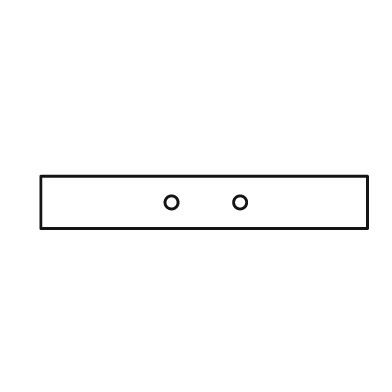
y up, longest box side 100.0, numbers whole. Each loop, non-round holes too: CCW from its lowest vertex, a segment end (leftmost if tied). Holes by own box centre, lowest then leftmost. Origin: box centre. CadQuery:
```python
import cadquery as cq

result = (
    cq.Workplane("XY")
    .moveTo(-50.0, -8.0)
    .lineTo(50.0, -8.0)
    .lineTo(50.0, 8.0)
    .lineTo(-50.0, 8.0)
    .close()
    .moveTo(-10.0, 0.0)
    .circle(2.0)
    .moveTo(11.0, 0.0)
    .circle(2.0)
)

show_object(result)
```